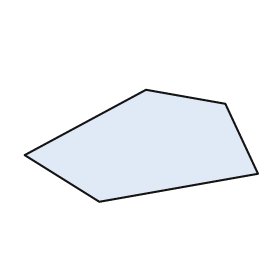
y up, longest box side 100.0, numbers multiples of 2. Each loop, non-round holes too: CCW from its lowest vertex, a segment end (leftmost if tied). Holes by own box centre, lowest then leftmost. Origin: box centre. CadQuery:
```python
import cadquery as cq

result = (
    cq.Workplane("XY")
    .moveTo(-18.0, -24.0)
    .lineTo(50.0, -12.0)
    .lineTo(36.0, 18.0)
    .lineTo(2.0, 24.0)
    .lineTo(-50.0, -4.0)
    .close()
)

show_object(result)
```